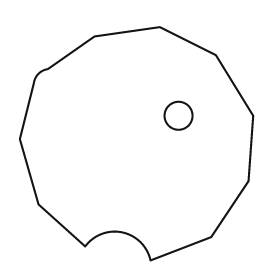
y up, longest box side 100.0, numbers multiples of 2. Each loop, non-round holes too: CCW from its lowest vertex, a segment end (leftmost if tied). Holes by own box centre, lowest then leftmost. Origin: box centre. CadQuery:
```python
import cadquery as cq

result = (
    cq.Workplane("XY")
    .moveTo(6.0, -50.0)
    .lineTo(32.0, -40.0)
    .lineTo(48.0, -16.0)
    .lineTo(50.0, 12.0)
    .lineTo(34.0, 38.0)
    .lineTo(10.0, 50.0)
    .lineTo(-18.0, 46.0)
    .lineTo(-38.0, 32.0)
    .threePointArc((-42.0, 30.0), (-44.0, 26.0))
    .lineTo(-50.0, 2.0)
    .lineTo(-42.0, -26.0)
    .lineTo(-22.0, -44.0)
    .threePointArc((-6.0, -38.0), (6.0, -50.0))
    .close()
    .moveTo(18.0, 12.0)
    .circle(6.0)
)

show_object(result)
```